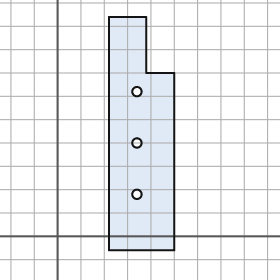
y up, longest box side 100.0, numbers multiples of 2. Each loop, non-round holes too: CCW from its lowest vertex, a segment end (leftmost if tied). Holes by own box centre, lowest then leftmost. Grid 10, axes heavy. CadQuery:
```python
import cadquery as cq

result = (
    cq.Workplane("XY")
    .moveTo(22.0, -6.0)
    .lineTo(50.0, -6.0)
    .lineTo(50.0, 70.0)
    .lineTo(38.0, 70.0)
    .lineTo(38.0, 94.0)
    .lineTo(22.0, 94.0)
    .close()
    .moveTo(34.0, 18.0)
    .circle(2.0)
    .moveTo(34.0, 40.0)
    .circle(2.0)
    .moveTo(34.0, 62.0)
    .circle(2.0)
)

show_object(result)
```